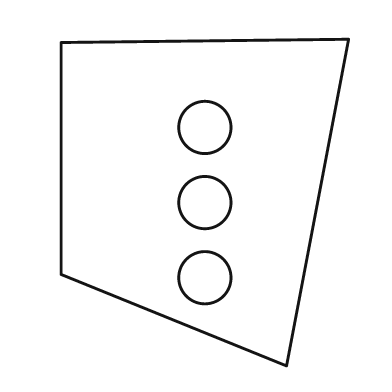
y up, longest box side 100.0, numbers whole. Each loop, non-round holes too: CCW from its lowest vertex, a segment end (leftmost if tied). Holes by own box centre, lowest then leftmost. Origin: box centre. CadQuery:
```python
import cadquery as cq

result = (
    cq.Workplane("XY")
    .moveTo(25.0, -50.0)
    .lineTo(44.0, 50.0)
    .lineTo(-44.0, 49.0)
    .lineTo(-44.0, -22.0)
    .close()
    .moveTo(0.0, -23.0)
    .circle(8.0)
    .moveTo(0.0, 0.0)
    .circle(8.0)
    .moveTo(0.0, 23.0)
    .circle(8.0)
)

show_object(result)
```